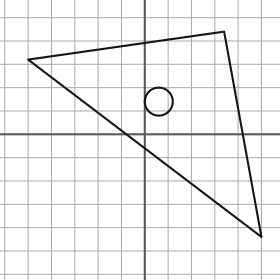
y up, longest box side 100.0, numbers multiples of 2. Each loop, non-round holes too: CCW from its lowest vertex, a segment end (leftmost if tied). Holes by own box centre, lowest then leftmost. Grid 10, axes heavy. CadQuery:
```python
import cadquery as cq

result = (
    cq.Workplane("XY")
    .moveTo(50.0, -44.0)
    .lineTo(34.0, 44.0)
    .lineTo(-50.0, 32.0)
    .close()
    .moveTo(6.0, 14.0)
    .circle(6.0)
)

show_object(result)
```